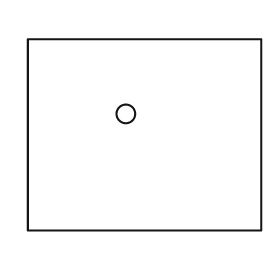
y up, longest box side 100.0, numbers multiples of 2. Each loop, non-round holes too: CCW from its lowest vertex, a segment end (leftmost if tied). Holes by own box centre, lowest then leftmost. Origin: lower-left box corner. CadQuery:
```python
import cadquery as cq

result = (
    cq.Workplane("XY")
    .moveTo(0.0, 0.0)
    .lineTo(100.0, 0.0)
    .lineTo(100.0, 82.0)
    .lineTo(0.0, 82.0)
    .close()
    .moveTo(42.0, 50.0)
    .circle(4.0)
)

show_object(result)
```